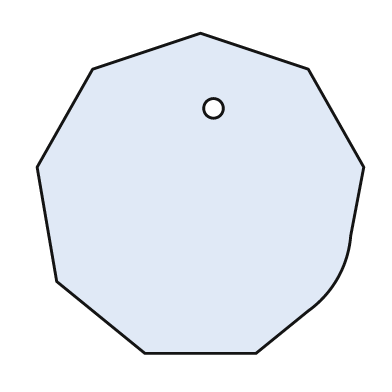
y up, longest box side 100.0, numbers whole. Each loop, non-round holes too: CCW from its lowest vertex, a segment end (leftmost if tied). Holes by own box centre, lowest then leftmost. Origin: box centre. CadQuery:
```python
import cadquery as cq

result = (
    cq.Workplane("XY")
    .moveTo(-17.0, -49.0)
    .lineTo(17.0, -49.0)
    .lineTo(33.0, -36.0)
    .threePointArc((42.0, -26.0), (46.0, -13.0))
    .lineTo(50.0, 8.0)
    .lineTo(33.0, 38.0)
    .lineTo(0.0, 49.0)
    .lineTo(-33.0, 38.0)
    .lineTo(-50.0, 8.0)
    .lineTo(-44.0, -27.0)
    .close()
    .moveTo(4.0, 26.0)
    .circle(3.0)
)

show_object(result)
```